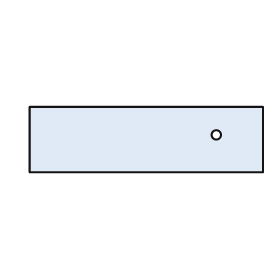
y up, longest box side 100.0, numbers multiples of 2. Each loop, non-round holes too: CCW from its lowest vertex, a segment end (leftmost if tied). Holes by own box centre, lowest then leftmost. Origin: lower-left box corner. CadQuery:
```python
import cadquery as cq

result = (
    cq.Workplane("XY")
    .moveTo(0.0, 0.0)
    .lineTo(100.0, 0.0)
    .lineTo(100.0, 28.0)
    .lineTo(0.0, 28.0)
    .close()
    .moveTo(80.0, 16.0)
    .circle(2.0)
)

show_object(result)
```